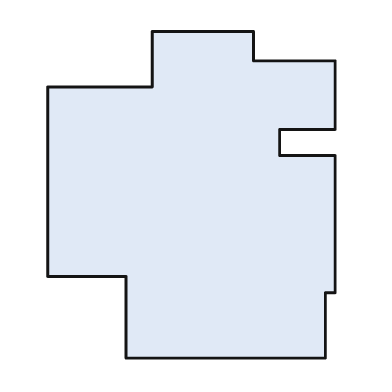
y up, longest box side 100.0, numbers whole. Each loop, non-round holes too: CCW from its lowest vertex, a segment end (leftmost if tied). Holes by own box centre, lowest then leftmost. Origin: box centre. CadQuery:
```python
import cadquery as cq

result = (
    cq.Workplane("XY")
    .moveTo(-20.0, -50.0)
    .lineTo(41.0, -50.0)
    .lineTo(41.0, -30.0)
    .lineTo(44.0, -30.0)
    .lineTo(44.0, 12.0)
    .lineTo(27.0, 12.0)
    .lineTo(27.0, 20.0)
    .lineTo(44.0, 20.0)
    .lineTo(44.0, 41.0)
    .lineTo(19.0, 41.0)
    .lineTo(19.0, 50.0)
    .lineTo(-12.0, 50.0)
    .lineTo(-12.0, 33.0)
    .lineTo(-44.0, 33.0)
    .lineTo(-44.0, -25.0)
    .lineTo(-20.0, -25.0)
    .close()
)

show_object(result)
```